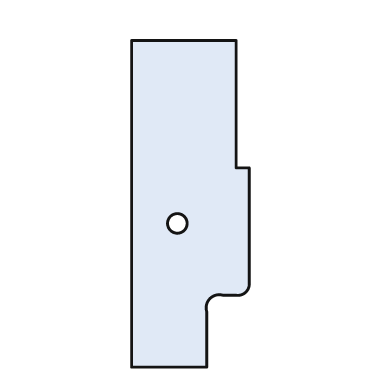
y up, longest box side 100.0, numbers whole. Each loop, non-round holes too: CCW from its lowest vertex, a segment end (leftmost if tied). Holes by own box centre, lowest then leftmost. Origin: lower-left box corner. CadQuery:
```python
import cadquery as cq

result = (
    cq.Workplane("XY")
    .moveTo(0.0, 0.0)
    .lineTo(23.0, 0.0)
    .lineTo(23.0, 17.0)
    .threePointArc((24.0, 21.0), (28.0, 22.0))
    .lineTo(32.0, 22.0)
    .threePointArc((35.0, 23.0), (36.0, 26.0))
    .lineTo(36.0, 61.0)
    .lineTo(32.0, 61.0)
    .lineTo(32.0, 100.0)
    .lineTo(0.0, 100.0)
    .close()
    .moveTo(14.0, 44.0)
    .circle(3.0)
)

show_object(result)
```